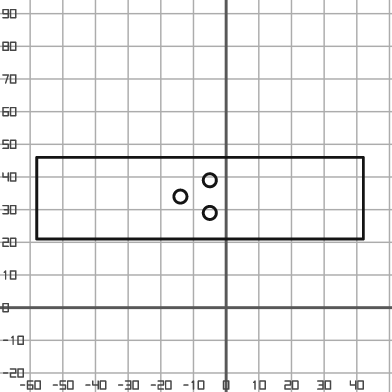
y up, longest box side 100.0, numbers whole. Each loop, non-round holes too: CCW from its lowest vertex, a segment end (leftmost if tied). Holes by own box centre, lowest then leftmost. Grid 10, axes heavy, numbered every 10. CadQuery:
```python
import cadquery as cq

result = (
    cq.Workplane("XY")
    .moveTo(-58.0, 21.0)
    .lineTo(42.0, 21.0)
    .lineTo(42.0, 46.0)
    .lineTo(-58.0, 46.0)
    .close()
    .moveTo(-5.0, 29.0)
    .circle(2.0)
    .moveTo(-14.0, 34.0)
    .circle(2.0)
    .moveTo(-5.0, 39.0)
    .circle(2.0)
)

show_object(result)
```